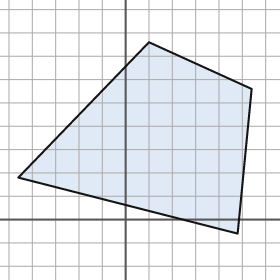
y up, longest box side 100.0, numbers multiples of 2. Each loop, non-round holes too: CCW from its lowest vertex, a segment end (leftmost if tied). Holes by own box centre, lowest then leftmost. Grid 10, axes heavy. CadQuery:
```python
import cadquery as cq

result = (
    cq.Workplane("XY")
    .moveTo(48.0, -6.0)
    .lineTo(54.0, 56.0)
    .lineTo(10.0, 76.0)
    .lineTo(-46.0, 18.0)
    .close()
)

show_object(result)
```